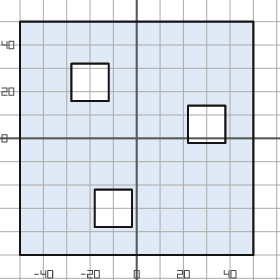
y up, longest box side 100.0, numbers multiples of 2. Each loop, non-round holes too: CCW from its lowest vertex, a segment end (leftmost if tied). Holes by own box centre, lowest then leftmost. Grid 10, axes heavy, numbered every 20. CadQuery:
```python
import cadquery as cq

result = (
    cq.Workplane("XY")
    .moveTo(-50.0, -50.0)
    .lineTo(50.0, -50.0)
    .lineTo(50.0, 50.0)
    .lineTo(-50.0, 50.0)
    .close()
    .moveTo(-18.0, -38.0)
    .lineTo(-2.0, -38.0)
    .lineTo(-2.0, -22.0)
    .lineTo(-18.0, -22.0)
    .close()
    .moveTo(22.0, -2.0)
    .lineTo(38.0, -2.0)
    .lineTo(38.0, 14.0)
    .lineTo(22.0, 14.0)
    .close()
    .moveTo(-28.0, 16.0)
    .lineTo(-12.0, 16.0)
    .lineTo(-12.0, 32.0)
    .lineTo(-28.0, 32.0)
    .close()
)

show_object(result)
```